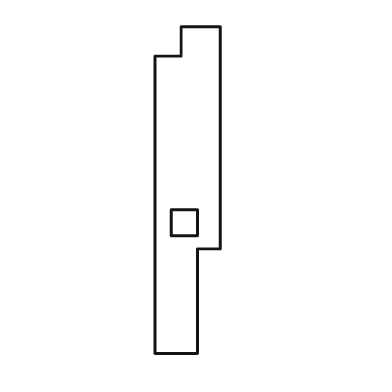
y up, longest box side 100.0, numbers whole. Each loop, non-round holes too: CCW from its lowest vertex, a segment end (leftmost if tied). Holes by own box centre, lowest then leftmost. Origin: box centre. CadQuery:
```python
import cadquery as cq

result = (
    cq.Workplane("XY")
    .moveTo(-10.0, -50.0)
    .lineTo(3.0, -50.0)
    .lineTo(3.0, -18.0)
    .lineTo(10.0, -18.0)
    .lineTo(10.0, 50.0)
    .lineTo(-2.0, 50.0)
    .lineTo(-2.0, 41.0)
    .lineTo(-10.0, 41.0)
    .close()
    .moveTo(-5.0, -14.0)
    .lineTo(3.0, -14.0)
    .lineTo(3.0, -6.0)
    .lineTo(-5.0, -6.0)
    .close()
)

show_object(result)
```